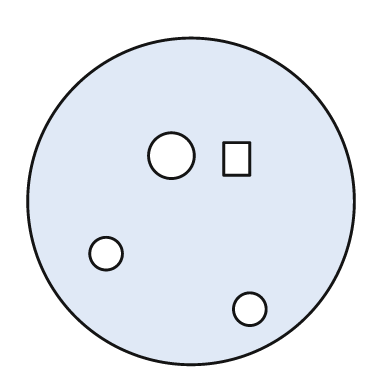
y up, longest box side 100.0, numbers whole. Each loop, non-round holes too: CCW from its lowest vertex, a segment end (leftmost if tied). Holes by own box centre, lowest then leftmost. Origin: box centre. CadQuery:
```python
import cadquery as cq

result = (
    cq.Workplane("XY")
    .moveTo(0.0, 0.0)
    .circle(50.0)
    .moveTo(18.0, -33.0)
    .circle(5.0)
    .moveTo(-26.0, -16.0)
    .circle(5.0)
    .moveTo(10.0, 8.0)
    .lineTo(18.0, 8.0)
    .lineTo(18.0, 18.0)
    .lineTo(10.0, 18.0)
    .close()
    .moveTo(-6.0, 14.0)
    .circle(7.0)
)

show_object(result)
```